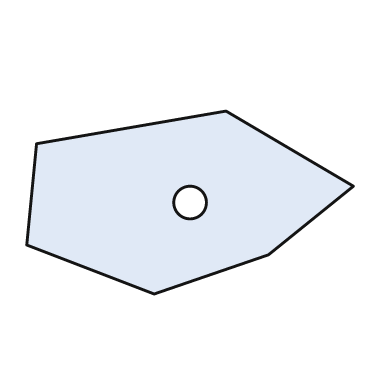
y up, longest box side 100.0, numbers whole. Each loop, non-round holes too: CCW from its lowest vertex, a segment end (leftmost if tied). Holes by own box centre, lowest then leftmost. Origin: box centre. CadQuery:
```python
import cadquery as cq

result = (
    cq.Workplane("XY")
    .moveTo(-11.0, -28.0)
    .lineTo(24.0, -16.0)
    .lineTo(50.0, 5.0)
    .lineTo(11.0, 28.0)
    .lineTo(-47.0, 18.0)
    .lineTo(-50.0, -13.0)
    .close()
    .moveTo(0.0, 0.0)
    .circle(5.0)
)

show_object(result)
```